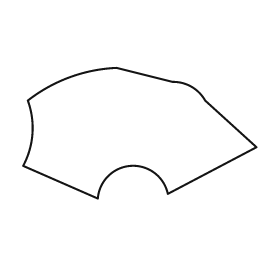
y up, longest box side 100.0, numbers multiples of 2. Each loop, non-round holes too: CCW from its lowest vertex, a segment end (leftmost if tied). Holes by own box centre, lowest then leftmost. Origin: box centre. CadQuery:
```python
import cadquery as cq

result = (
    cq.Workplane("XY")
    .moveTo(-18.0, -28.0)
    .threePointArc((-4.0, -14.0), (12.0, -26.0))
    .lineTo(50.0, -6.0)
    .lineTo(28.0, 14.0)
    .threePointArc((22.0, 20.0), (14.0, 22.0))
    .lineTo(-10.0, 28.0)
    .threePointArc((-30.0, 24.0), (-48.0, 14.0))
    .threePointArc((-46.0, 0.0), (-50.0, -14.0))
    .close()
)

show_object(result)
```